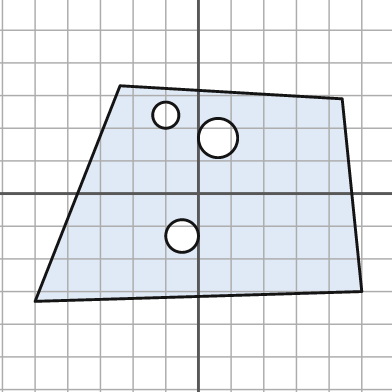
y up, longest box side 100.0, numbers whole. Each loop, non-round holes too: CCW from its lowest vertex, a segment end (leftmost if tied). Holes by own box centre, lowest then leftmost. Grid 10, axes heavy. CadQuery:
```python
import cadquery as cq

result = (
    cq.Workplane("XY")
    .moveTo(-50.0, -33.0)
    .lineTo(50.0, -30.0)
    .lineTo(44.0, 29.0)
    .lineTo(-24.0, 33.0)
    .close()
    .moveTo(-5.0, -13.0)
    .circle(5.0)
    .moveTo(6.0, 17.0)
    .circle(6.0)
    .moveTo(-10.0, 24.0)
    .circle(4.0)
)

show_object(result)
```